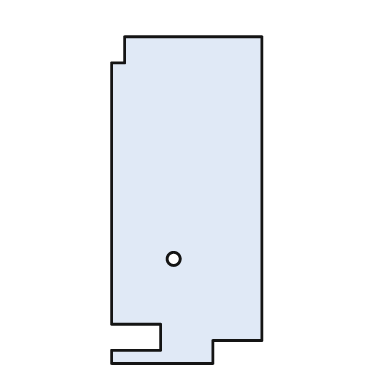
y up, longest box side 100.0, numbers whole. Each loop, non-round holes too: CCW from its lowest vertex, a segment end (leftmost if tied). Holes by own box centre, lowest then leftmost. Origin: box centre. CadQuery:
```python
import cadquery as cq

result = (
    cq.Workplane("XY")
    .moveTo(-23.0, -50.0)
    .lineTo(8.0, -50.0)
    .lineTo(8.0, -43.0)
    .lineTo(23.0, -43.0)
    .lineTo(23.0, 50.0)
    .lineTo(-19.0, 50.0)
    .lineTo(-19.0, 42.0)
    .lineTo(-23.0, 42.0)
    .lineTo(-23.0, -38.0)
    .lineTo(-8.0, -38.0)
    .lineTo(-8.0, -46.0)
    .lineTo(-23.0, -46.0)
    .close()
    .moveTo(-4.0, -18.0)
    .circle(2.0)
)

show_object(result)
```